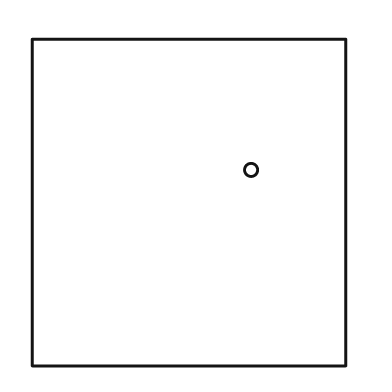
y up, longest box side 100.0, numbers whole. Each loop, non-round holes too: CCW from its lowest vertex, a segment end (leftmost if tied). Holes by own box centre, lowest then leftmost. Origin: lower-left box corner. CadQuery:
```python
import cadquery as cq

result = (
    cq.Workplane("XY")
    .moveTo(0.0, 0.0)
    .lineTo(96.0, 0.0)
    .lineTo(96.0, 100.0)
    .lineTo(0.0, 100.0)
    .close()
    .moveTo(67.0, 60.0)
    .circle(2.0)
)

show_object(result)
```